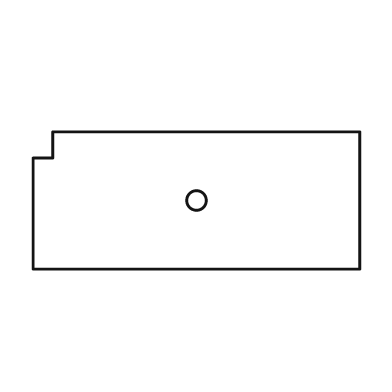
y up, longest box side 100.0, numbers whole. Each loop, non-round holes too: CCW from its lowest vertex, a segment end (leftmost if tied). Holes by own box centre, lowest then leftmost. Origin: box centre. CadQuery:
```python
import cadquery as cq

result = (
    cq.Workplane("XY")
    .moveTo(-50.0, -21.0)
    .lineTo(50.0, -21.0)
    .lineTo(50.0, 21.0)
    .lineTo(-44.0, 21.0)
    .lineTo(-44.0, 13.0)
    .lineTo(-50.0, 13.0)
    .close()
    .moveTo(0.0, 0.0)
    .circle(3.0)
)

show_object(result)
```